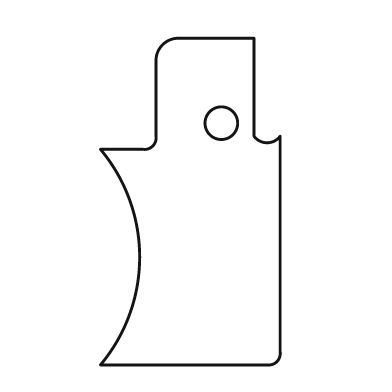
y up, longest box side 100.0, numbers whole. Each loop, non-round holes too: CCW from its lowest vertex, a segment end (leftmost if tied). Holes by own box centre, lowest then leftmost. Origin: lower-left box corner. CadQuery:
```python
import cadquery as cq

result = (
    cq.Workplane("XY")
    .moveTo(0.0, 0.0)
    .lineTo(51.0, 0.0)
    .threePointArc((54.0, 1.0), (55.0, 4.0))
    .lineTo(55.0, 70.0)
    .threePointArc((51.0, 68.0), (47.0, 70.0))
    .lineTo(47.0, 100.0)
    .lineTo(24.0, 100.0)
    .threePointArc((19.0, 98.0), (17.0, 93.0))
    .lineTo(17.0, 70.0)
    .threePointArc((16.0, 67.0), (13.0, 66.0))
    .lineTo(0.0, 66.0)
    .threePointArc((12.0, 33.0), (0.0, 0.0))
    .close()
    .moveTo(37.0, 74.0)
    .circle(5.0)
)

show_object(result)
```